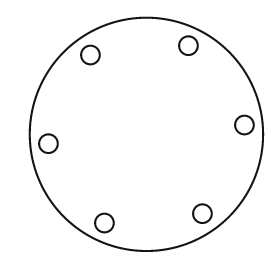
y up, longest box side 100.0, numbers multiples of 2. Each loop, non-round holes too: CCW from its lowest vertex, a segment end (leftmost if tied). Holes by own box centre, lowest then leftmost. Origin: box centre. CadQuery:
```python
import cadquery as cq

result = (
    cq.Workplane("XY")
    .moveTo(0.0, 0.0)
    .circle(50.0)
    .moveTo(-18.0, -38.0)
    .circle(4.0)
    .moveTo(24.0, -34.0)
    .circle(4.0)
    .moveTo(-42.0, -4.0)
    .circle(4.0)
    .moveTo(42.0, 4.0)
    .circle(4.0)
    .moveTo(-24.0, 34.0)
    .circle(4.0)
    .moveTo(18.0, 38.0)
    .circle(4.0)
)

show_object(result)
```